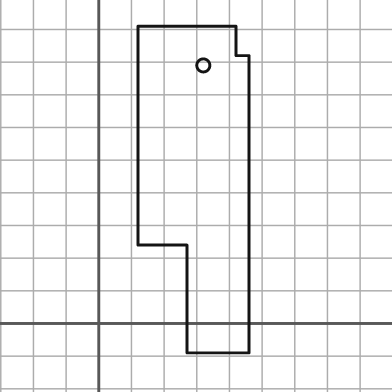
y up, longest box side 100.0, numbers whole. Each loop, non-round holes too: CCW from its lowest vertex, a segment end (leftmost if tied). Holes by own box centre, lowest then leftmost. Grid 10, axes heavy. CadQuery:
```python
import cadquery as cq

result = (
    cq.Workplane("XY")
    .moveTo(27.0, -9.0)
    .lineTo(46.0, -9.0)
    .lineTo(46.0, 82.0)
    .lineTo(42.0, 82.0)
    .lineTo(42.0, 91.0)
    .lineTo(12.0, 91.0)
    .lineTo(12.0, 24.0)
    .lineTo(27.0, 24.0)
    .close()
    .moveTo(32.0, 79.0)
    .circle(2.0)
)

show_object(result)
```